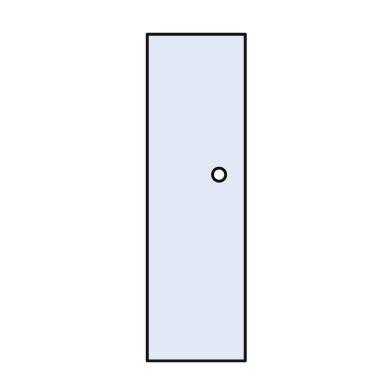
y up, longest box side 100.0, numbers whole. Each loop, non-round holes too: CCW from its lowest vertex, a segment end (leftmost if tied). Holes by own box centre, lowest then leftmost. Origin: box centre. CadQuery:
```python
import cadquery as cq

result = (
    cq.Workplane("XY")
    .moveTo(-15.0, -50.0)
    .lineTo(15.0, -50.0)
    .lineTo(15.0, 50.0)
    .lineTo(-15.0, 50.0)
    .close()
    .moveTo(7.0, 7.0)
    .circle(2.0)
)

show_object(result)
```